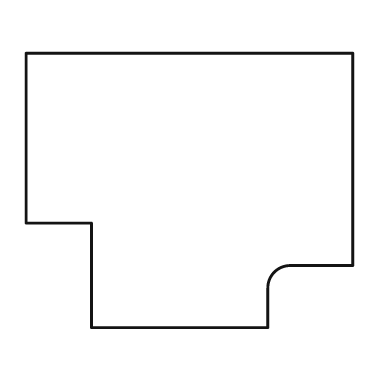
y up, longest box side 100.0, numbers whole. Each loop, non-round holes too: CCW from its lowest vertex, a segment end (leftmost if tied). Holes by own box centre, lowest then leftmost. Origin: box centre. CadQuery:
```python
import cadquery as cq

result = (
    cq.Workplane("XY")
    .moveTo(-30.0, -42.0)
    .lineTo(24.0, -42.0)
    .lineTo(24.0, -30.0)
    .threePointArc((26.0, -25.0), (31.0, -23.0))
    .lineTo(50.0, -23.0)
    .lineTo(50.0, 42.0)
    .lineTo(-50.0, 42.0)
    .lineTo(-50.0, -10.0)
    .lineTo(-30.0, -10.0)
    .close()
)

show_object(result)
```